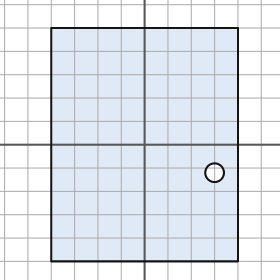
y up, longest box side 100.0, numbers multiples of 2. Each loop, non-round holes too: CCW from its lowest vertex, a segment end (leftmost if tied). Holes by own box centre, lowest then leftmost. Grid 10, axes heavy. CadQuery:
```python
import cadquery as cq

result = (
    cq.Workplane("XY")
    .moveTo(-40.0, -50.0)
    .lineTo(40.0, -50.0)
    .lineTo(40.0, 50.0)
    .lineTo(-40.0, 50.0)
    .close()
    .moveTo(30.0, -12.0)
    .circle(4.0)
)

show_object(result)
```